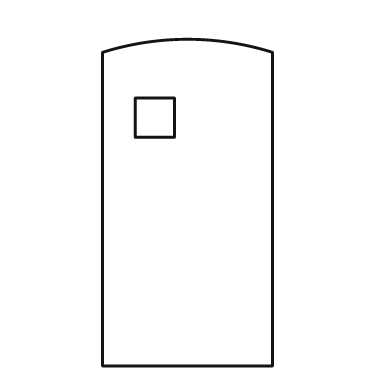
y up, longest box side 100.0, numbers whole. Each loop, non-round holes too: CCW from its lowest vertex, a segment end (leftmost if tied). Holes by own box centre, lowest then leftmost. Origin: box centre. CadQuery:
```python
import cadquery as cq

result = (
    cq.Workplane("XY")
    .moveTo(-26.0, -50.0)
    .lineTo(26.0, -50.0)
    .lineTo(26.0, 46.0)
    .threePointArc((0.0, 50.0), (-26.0, 46.0))
    .close()
    .moveTo(-16.0, 20.0)
    .lineTo(-4.0, 20.0)
    .lineTo(-4.0, 32.0)
    .lineTo(-16.0, 32.0)
    .close()
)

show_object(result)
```